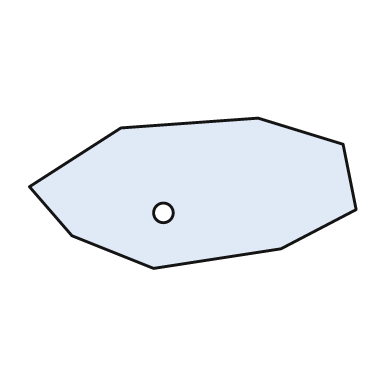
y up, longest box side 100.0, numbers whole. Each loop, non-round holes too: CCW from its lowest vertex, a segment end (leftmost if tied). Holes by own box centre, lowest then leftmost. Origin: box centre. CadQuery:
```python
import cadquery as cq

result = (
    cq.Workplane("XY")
    .moveTo(-12.0, -23.0)
    .lineTo(27.0, -17.0)
    .lineTo(50.0, -5.0)
    .lineTo(46.0, 15.0)
    .lineTo(20.0, 23.0)
    .lineTo(-22.0, 20.0)
    .lineTo(-50.0, 2.0)
    .lineTo(-37.0, -13.0)
    .close()
    .moveTo(-9.0, -6.0)
    .circle(3.0)
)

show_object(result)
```